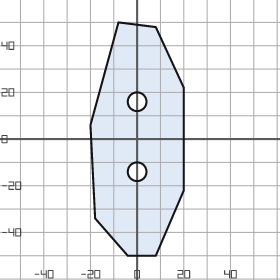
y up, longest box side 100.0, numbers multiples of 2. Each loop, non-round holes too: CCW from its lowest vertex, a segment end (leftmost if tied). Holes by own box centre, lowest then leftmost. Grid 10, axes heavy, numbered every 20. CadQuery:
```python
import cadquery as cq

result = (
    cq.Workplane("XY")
    .moveTo(-4.0, -50.0)
    .lineTo(8.0, -50.0)
    .lineTo(20.0, -22.0)
    .lineTo(20.0, 22.0)
    .lineTo(8.0, 48.0)
    .lineTo(-8.0, 50.0)
    .lineTo(-20.0, 6.0)
    .lineTo(-18.0, -34.0)
    .close()
    .moveTo(0.0, -14.0)
    .circle(4.0)
    .moveTo(0.0, 16.0)
    .circle(4.0)
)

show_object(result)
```